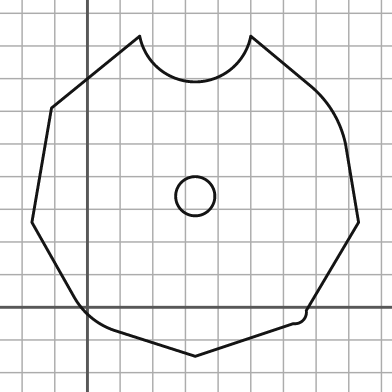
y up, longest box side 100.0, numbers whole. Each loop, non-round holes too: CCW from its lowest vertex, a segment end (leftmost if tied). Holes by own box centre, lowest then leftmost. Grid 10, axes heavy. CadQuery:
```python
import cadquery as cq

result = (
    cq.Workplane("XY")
    .moveTo(33.0, -15.0)
    .lineTo(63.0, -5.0)
    .threePointArc((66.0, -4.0), (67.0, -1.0))
    .lineTo(83.0, 26.0)
    .lineTo(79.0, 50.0)
    .threePointArc((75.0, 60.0), (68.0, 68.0))
    .lineTo(50.0, 83.0)
    .threePointArc((33.0, 69.0), (16.0, 83.0))
    .lineTo(-11.0, 61.0)
    .lineTo(-17.0, 26.0)
    .lineTo(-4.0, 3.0)
    .threePointArc((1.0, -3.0), (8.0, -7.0))
    .close()
    .moveTo(33.0, 34.0)
    .circle(6.0)
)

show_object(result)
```